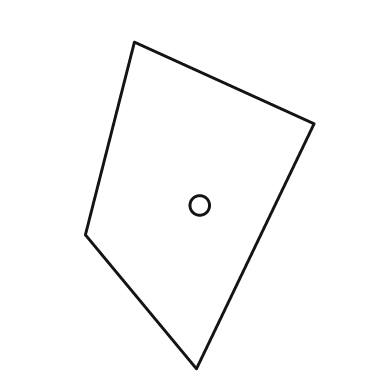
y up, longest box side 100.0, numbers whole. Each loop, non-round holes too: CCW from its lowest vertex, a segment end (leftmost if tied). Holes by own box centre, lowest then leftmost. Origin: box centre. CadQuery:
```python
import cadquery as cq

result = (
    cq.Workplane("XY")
    .moveTo(-1.0, -50.0)
    .lineTo(35.0, 25.0)
    .lineTo(-20.0, 50.0)
    .lineTo(-35.0, -9.0)
    .close()
    .moveTo(0.0, 0.0)
    .circle(3.0)
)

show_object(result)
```